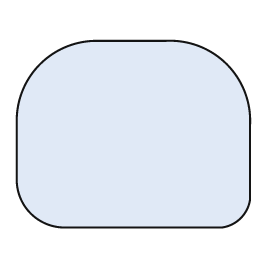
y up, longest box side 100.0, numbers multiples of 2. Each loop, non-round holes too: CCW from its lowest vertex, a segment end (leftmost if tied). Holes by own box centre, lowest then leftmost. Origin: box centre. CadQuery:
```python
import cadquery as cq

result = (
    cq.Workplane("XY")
    .moveTo(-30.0, -40.0)
    .lineTo(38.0, -40.0)
    .threePointArc((46.0, -36.0), (50.0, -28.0))
    .lineTo(50.0, 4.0)
    .threePointArc((40.0, 30.0), (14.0, 40.0))
    .lineTo(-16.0, 40.0)
    .threePointArc((-40.0, 30.0), (-50.0, 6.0))
    .lineTo(-50.0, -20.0)
    .threePointArc((-44.0, -34.0), (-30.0, -40.0))
    .close()
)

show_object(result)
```